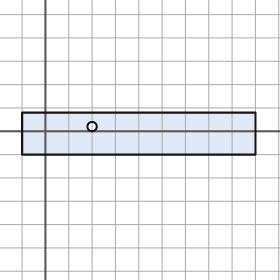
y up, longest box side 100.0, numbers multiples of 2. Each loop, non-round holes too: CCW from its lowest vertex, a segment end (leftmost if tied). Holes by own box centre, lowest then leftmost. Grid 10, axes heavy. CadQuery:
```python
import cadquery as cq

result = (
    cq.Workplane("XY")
    .moveTo(-10.0, -10.0)
    .lineTo(90.0, -10.0)
    .lineTo(90.0, 8.0)
    .lineTo(-10.0, 8.0)
    .close()
    .moveTo(20.0, 2.0)
    .circle(2.0)
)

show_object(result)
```